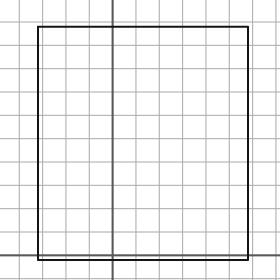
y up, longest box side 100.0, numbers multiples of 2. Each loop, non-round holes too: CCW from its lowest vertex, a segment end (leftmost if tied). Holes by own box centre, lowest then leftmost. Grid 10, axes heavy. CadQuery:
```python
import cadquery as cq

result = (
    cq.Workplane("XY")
    .moveTo(-32.0, -2.0)
    .lineTo(58.0, -2.0)
    .lineTo(58.0, 98.0)
    .lineTo(-32.0, 98.0)
    .close()
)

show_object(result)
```